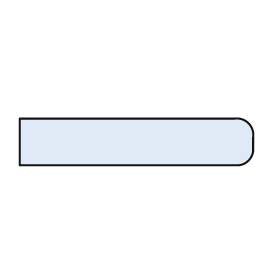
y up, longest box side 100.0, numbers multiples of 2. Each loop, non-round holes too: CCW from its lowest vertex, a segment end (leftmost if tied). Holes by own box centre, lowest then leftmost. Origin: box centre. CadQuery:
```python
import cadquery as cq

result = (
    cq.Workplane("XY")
    .moveTo(-50.0, -10.0)
    .lineTo(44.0, -10.0)
    .threePointArc((48.0, -8.0), (50.0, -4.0))
    .lineTo(50.0, 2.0)
    .threePointArc((48.0, 8.0), (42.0, 10.0))
    .lineTo(-50.0, 10.0)
    .close()
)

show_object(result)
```